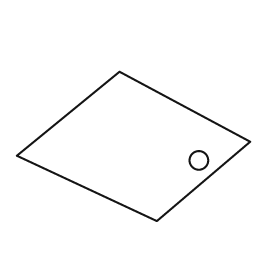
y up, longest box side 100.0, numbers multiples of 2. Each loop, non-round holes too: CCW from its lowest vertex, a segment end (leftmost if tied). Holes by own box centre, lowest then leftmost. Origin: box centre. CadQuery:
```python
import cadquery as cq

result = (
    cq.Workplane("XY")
    .moveTo(10.0, -32.0)
    .lineTo(50.0, 2.0)
    .lineTo(-6.0, 32.0)
    .lineTo(-50.0, -4.0)
    .close()
    .moveTo(28.0, -6.0)
    .circle(4.0)
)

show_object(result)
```